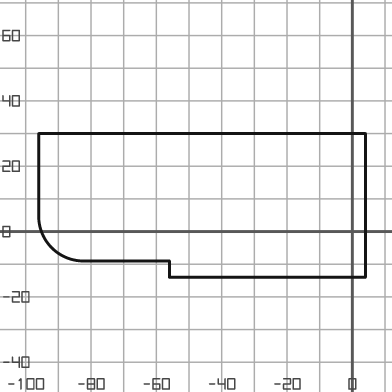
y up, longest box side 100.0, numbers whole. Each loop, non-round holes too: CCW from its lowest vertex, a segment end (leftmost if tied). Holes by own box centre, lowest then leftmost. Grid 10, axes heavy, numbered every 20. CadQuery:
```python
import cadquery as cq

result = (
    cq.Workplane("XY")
    .moveTo(-56.0, -14.0)
    .lineTo(4.0, -14.0)
    .lineTo(4.0, 30.0)
    .lineTo(-96.0, 30.0)
    .lineTo(-96.0, 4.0)
    .threePointArc((-92.0, -5.0), (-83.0, -9.0))
    .lineTo(-56.0, -9.0)
    .close()
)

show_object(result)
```